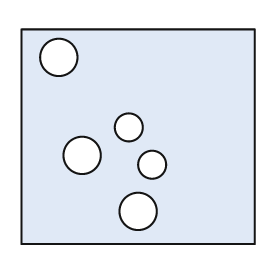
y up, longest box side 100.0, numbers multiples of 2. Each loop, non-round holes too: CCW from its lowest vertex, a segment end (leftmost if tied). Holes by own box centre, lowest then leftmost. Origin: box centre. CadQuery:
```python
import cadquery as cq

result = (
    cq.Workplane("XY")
    .moveTo(-50.0, -46.0)
    .lineTo(50.0, -46.0)
    .lineTo(50.0, 46.0)
    .lineTo(-50.0, 46.0)
    .close()
    .moveTo(0.0, -32.0)
    .circle(8.0)
    .moveTo(6.0, -12.0)
    .circle(6.0)
    .moveTo(-24.0, -8.0)
    .circle(8.0)
    .moveTo(-4.0, 4.0)
    .circle(6.0)
    .moveTo(-34.0, 34.0)
    .circle(8.0)
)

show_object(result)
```